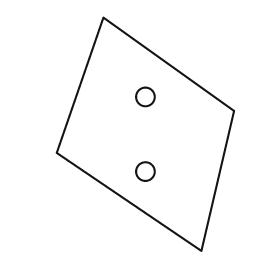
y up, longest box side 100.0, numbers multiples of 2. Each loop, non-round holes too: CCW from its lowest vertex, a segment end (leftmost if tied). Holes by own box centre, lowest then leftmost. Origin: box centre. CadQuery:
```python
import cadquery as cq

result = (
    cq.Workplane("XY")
    .moveTo(24.0, -50.0)
    .lineTo(38.0, 10.0)
    .lineTo(-18.0, 50.0)
    .lineTo(-38.0, -8.0)
    .close()
    .moveTo(0.0, -16.0)
    .circle(4.0)
    .moveTo(0.0, 16.0)
    .circle(4.0)
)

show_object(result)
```